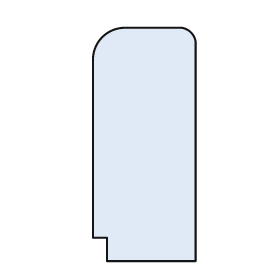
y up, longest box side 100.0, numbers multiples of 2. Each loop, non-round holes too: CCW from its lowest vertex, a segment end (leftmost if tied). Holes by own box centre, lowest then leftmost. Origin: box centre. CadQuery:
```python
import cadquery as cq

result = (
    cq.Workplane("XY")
    .moveTo(-16.0, -50.0)
    .lineTo(22.0, -50.0)
    .lineTo(22.0, 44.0)
    .threePointArc((20.0, 48.0), (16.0, 50.0))
    .lineTo(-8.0, 50.0)
    .threePointArc((-18.0, 46.0), (-22.0, 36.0))
    .lineTo(-22.0, -40.0)
    .lineTo(-16.0, -40.0)
    .close()
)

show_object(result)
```